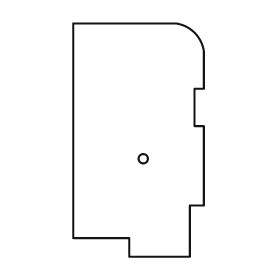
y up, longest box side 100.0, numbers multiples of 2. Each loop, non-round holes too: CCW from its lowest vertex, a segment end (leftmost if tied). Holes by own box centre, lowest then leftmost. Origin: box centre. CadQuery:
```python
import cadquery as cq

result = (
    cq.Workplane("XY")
    .moveTo(-4.0, -50.0)
    .lineTo(22.0, -50.0)
    .lineTo(22.0, -28.0)
    .lineTo(28.0, -28.0)
    .lineTo(28.0, 6.0)
    .lineTo(24.0, 6.0)
    .lineTo(24.0, 22.0)
    .lineTo(28.0, 22.0)
    .lineTo(28.0, 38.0)
    .threePointArc((24.0, 46.0), (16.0, 50.0))
    .lineTo(-28.0, 50.0)
    .lineTo(-28.0, -42.0)
    .lineTo(-4.0, -42.0)
    .close()
    .moveTo(2.0, -8.0)
    .circle(2.0)
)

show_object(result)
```